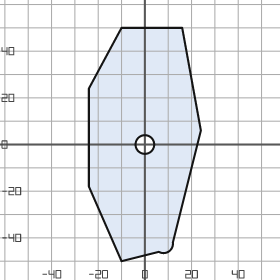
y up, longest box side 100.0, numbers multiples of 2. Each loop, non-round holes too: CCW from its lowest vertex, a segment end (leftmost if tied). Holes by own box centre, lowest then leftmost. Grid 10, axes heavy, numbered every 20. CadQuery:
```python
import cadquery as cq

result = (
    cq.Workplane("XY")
    .moveTo(-10.0, -50.0)
    .lineTo(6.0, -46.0)
    .threePointArc((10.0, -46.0), (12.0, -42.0))
    .lineTo(24.0, 6.0)
    .lineTo(16.0, 50.0)
    .lineTo(-10.0, 50.0)
    .lineTo(-24.0, 24.0)
    .lineTo(-24.0, -18.0)
    .close()
    .moveTo(0.0, 0.0)
    .circle(4.0)
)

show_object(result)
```